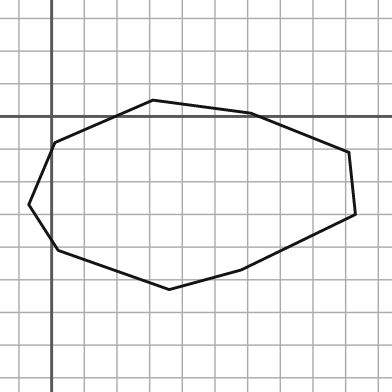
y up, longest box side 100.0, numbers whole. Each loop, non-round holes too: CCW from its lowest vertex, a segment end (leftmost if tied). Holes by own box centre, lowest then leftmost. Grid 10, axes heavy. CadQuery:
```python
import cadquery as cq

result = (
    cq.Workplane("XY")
    .moveTo(36.0, -53.0)
    .lineTo(58.0, -47.0)
    .lineTo(93.0, -30.0)
    .lineTo(91.0, -11.0)
    .lineTo(61.0, 1.0)
    .lineTo(31.0, 5.0)
    .lineTo(1.0, -8.0)
    .lineTo(-7.0, -27.0)
    .lineTo(2.0, -41.0)
    .close()
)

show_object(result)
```